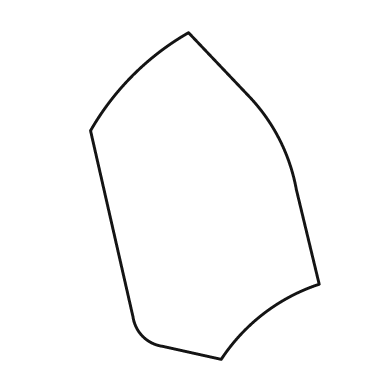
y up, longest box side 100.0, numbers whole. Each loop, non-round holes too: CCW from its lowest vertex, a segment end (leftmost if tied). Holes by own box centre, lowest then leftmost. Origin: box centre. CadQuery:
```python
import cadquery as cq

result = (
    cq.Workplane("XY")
    .moveTo(5.0, -50.0)
    .threePointArc((18.0, -36.0), (35.0, -27.0))
    .lineTo(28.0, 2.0)
    .threePointArc((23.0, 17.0), (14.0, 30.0))
    .lineTo(-5.0, 50.0)
    .threePointArc((-22.0, 37.0), (-35.0, 20.0))
    .lineTo(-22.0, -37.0)
    .threePointArc((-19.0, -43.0), (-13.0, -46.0))
    .close()
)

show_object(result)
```